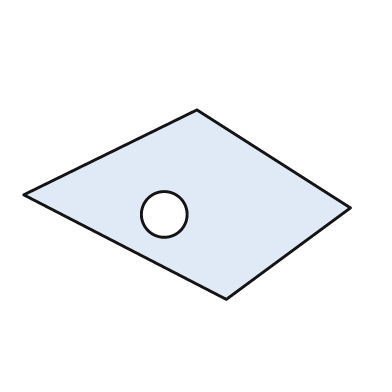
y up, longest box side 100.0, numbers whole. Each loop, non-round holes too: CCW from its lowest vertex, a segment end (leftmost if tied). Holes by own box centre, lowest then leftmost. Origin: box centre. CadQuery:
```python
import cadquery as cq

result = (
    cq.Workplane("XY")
    .moveTo(12.0, -29.0)
    .lineTo(50.0, -1.0)
    .lineTo(3.0, 29.0)
    .lineTo(-50.0, 3.0)
    .close()
    .moveTo(-7.0, -3.0)
    .circle(7.0)
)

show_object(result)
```